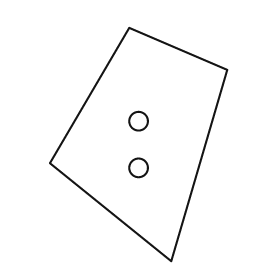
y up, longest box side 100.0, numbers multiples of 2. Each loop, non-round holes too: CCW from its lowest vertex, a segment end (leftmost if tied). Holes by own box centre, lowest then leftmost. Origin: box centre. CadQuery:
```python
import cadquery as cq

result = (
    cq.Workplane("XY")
    .moveTo(14.0, -50.0)
    .lineTo(38.0, 32.0)
    .lineTo(-4.0, 50.0)
    .lineTo(-38.0, -8.0)
    .close()
    .moveTo(0.0, -10.0)
    .circle(4.0)
    .moveTo(0.0, 10.0)
    .circle(4.0)
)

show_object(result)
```